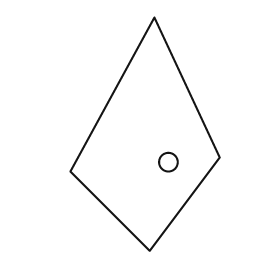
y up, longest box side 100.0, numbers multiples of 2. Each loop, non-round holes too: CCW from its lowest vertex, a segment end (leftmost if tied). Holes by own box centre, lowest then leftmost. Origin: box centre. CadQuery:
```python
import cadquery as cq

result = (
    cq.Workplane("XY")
    .moveTo(2.0, -50.0)
    .lineTo(32.0, -10.0)
    .lineTo(4.0, 50.0)
    .lineTo(-32.0, -16.0)
    .close()
    .moveTo(10.0, -12.0)
    .circle(4.0)
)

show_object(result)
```